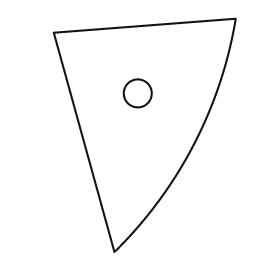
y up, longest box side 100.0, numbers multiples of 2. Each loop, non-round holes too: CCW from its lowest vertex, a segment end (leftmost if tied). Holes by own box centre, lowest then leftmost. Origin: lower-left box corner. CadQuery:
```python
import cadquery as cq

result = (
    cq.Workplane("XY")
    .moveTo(26.0, 0.0)
    .threePointArc((60.0, 46.0), (78.0, 100.0))
    .lineTo(0.0, 94.0)
    .close()
    .moveTo(36.0, 68.0)
    .circle(6.0)
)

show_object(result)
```